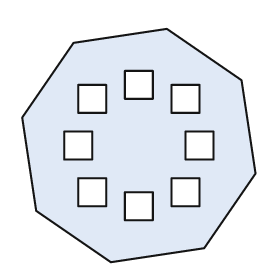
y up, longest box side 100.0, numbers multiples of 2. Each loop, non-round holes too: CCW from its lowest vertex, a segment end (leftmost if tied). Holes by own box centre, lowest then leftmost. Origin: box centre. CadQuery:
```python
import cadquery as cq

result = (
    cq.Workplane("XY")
    .moveTo(-12.0, -50.0)
    .lineTo(28.0, -44.0)
    .lineTo(50.0, -12.0)
    .lineTo(44.0, 28.0)
    .lineTo(12.0, 50.0)
    .lineTo(-28.0, 44.0)
    .lineTo(-50.0, 12.0)
    .lineTo(-44.0, -28.0)
    .close()
    .moveTo(-6.0, -32.0)
    .lineTo(6.0, -32.0)
    .lineTo(6.0, -20.0)
    .lineTo(-6.0, -20.0)
    .close()
    .moveTo(-26.0, -26.0)
    .lineTo(-14.0, -26.0)
    .lineTo(-14.0, -14.0)
    .lineTo(-26.0, -14.0)
    .close()
    .moveTo(14.0, -26.0)
    .lineTo(26.0, -26.0)
    .lineTo(26.0, -14.0)
    .lineTo(14.0, -14.0)
    .close()
    .moveTo(-32.0, -6.0)
    .lineTo(-20.0, -6.0)
    .lineTo(-20.0, 6.0)
    .lineTo(-32.0, 6.0)
    .close()
    .moveTo(20.0, -6.0)
    .lineTo(32.0, -6.0)
    .lineTo(32.0, 6.0)
    .lineTo(20.0, 6.0)
    .close()
    .moveTo(-26.0, 14.0)
    .lineTo(-14.0, 14.0)
    .lineTo(-14.0, 26.0)
    .lineTo(-26.0, 26.0)
    .close()
    .moveTo(14.0, 14.0)
    .lineTo(26.0, 14.0)
    .lineTo(26.0, 26.0)
    .lineTo(14.0, 26.0)
    .close()
    .moveTo(-6.0, 20.0)
    .lineTo(6.0, 20.0)
    .lineTo(6.0, 32.0)
    .lineTo(-6.0, 32.0)
    .close()
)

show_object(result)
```